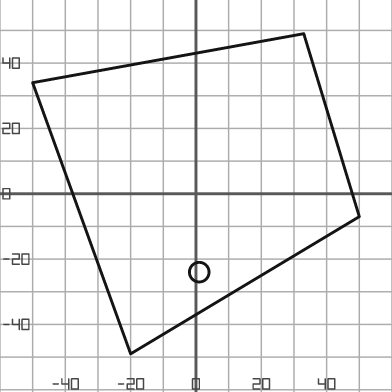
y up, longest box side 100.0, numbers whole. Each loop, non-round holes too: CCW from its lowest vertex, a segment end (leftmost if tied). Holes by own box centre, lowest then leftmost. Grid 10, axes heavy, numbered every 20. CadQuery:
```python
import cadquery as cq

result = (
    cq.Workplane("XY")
    .moveTo(-20.0, -49.0)
    .lineTo(50.0, -7.0)
    .lineTo(33.0, 49.0)
    .lineTo(-50.0, 34.0)
    .close()
    .moveTo(1.0, -24.0)
    .circle(3.0)
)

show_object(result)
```